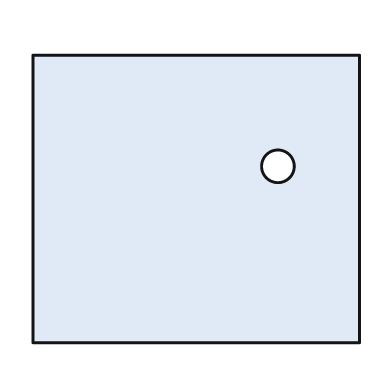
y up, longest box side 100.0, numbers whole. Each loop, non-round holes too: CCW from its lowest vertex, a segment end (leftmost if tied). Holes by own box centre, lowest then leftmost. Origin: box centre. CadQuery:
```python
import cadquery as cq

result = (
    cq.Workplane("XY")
    .moveTo(-50.0, -44.0)
    .lineTo(50.0, -44.0)
    .lineTo(50.0, 44.0)
    .lineTo(-50.0, 44.0)
    .close()
    .moveTo(25.0, 10.0)
    .circle(5.0)
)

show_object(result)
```